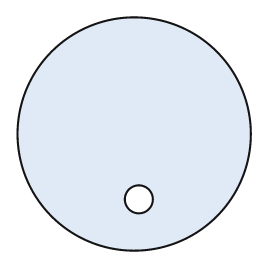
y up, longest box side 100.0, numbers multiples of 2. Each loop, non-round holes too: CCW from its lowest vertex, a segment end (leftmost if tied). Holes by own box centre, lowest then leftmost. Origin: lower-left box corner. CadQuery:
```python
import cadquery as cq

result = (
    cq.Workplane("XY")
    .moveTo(50.0, 50.0)
    .circle(50.0)
    .moveTo(52.0, 22.0)
    .circle(6.0)
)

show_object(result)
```